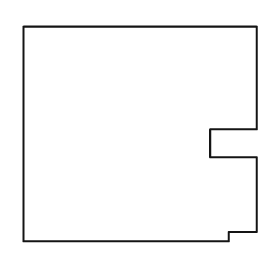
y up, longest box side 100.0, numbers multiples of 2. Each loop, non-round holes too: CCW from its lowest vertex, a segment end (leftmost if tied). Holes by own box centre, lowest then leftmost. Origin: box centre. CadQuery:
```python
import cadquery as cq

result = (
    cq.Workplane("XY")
    .moveTo(-50.0, -46.0)
    .lineTo(38.0, -46.0)
    .lineTo(38.0, -42.0)
    .lineTo(50.0, -42.0)
    .lineTo(50.0, -10.0)
    .lineTo(30.0, -10.0)
    .lineTo(30.0, 2.0)
    .lineTo(50.0, 2.0)
    .lineTo(50.0, 46.0)
    .lineTo(-50.0, 46.0)
    .close()
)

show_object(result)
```